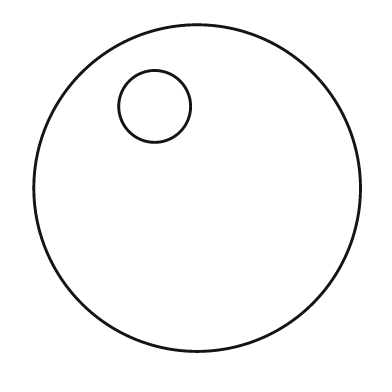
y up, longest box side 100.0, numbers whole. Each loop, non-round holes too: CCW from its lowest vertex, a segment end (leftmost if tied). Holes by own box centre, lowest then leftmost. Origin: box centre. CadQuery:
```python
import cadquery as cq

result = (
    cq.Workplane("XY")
    .moveTo(0.0, 0.0)
    .circle(50.0)
    .moveTo(-13.0, 25.0)
    .circle(11.0)
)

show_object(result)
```